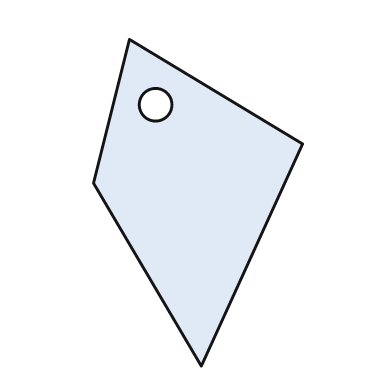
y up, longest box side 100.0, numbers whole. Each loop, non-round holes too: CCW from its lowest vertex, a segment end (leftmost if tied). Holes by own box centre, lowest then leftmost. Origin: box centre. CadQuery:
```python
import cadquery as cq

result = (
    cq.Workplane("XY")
    .moveTo(1.0, -50.0)
    .lineTo(32.0, 18.0)
    .lineTo(-21.0, 50.0)
    .lineTo(-32.0, 6.0)
    .close()
    .moveTo(-13.0, 30.0)
    .circle(5.0)
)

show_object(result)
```